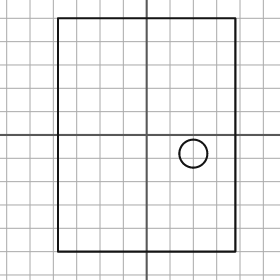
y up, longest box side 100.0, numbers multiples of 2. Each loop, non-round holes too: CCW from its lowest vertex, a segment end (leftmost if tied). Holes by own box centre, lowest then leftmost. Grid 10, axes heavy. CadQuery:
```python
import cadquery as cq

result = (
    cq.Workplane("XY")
    .moveTo(-38.0, -50.0)
    .lineTo(38.0, -50.0)
    .lineTo(38.0, 50.0)
    .lineTo(-38.0, 50.0)
    .close()
    .moveTo(20.0, -8.0)
    .circle(6.0)
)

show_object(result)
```